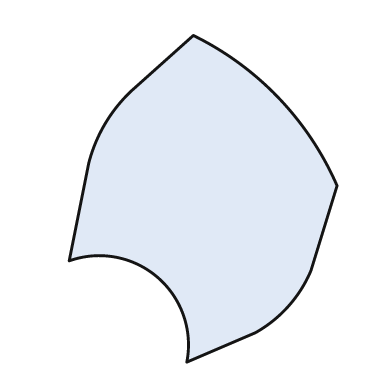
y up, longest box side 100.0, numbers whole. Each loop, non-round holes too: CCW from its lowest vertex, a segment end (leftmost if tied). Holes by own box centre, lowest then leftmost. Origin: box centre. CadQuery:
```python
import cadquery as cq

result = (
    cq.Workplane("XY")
    .moveTo(-5.0, -50.0)
    .lineTo(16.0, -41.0)
    .threePointArc((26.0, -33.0), (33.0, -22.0))
    .lineTo(41.0, 4.0)
    .threePointArc((23.0, 31.0), (-3.0, 50.0))
    .lineTo(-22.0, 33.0)
    .threePointArc((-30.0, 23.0), (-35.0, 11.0))
    .lineTo(-41.0, -19.0)
    .threePointArc((-14.0, -24.0), (-5.0, -50.0))
    .close()
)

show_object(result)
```